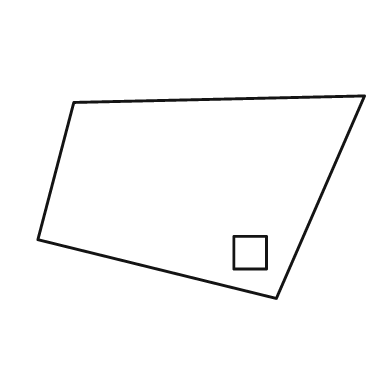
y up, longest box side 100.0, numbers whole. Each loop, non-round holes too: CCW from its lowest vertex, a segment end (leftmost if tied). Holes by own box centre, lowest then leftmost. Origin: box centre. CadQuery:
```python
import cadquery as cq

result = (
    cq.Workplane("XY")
    .moveTo(23.0, -31.0)
    .lineTo(50.0, 31.0)
    .lineTo(-39.0, 29.0)
    .lineTo(-50.0, -13.0)
    .close()
    .moveTo(10.0, -22.0)
    .lineTo(20.0, -22.0)
    .lineTo(20.0, -12.0)
    .lineTo(10.0, -12.0)
    .close()
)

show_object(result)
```